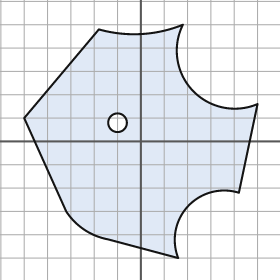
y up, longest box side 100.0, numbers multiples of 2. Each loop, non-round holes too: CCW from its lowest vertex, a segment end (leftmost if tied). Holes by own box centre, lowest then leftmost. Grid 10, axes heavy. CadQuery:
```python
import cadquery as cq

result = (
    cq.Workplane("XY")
    .moveTo(16.0, -50.0)
    .threePointArc((20.0, -28.0), (42.0, -22.0))
    .lineTo(50.0, 16.0)
    .threePointArc((22.0, 22.0), (18.0, 50.0))
    .threePointArc((0.0, 46.0), (-18.0, 48.0))
    .lineTo(-50.0, 10.0)
    .lineTo(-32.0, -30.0)
    .threePointArc((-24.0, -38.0), (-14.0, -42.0))
    .close()
    .moveTo(-10.0, 8.0)
    .circle(4.0)
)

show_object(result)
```